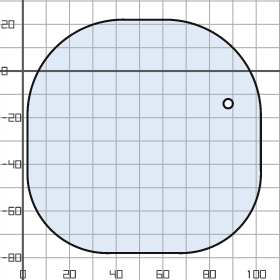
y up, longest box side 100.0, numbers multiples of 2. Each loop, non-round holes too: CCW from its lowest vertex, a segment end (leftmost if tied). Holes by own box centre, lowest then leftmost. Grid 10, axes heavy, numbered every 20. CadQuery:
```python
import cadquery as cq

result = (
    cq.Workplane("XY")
    .moveTo(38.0, -78.0)
    .lineTo(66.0, -78.0)
    .threePointArc((92.0, -68.0), (102.0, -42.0))
    .lineTo(102.0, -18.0)
    .threePointArc((90.0, 10.0), (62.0, 22.0))
    .lineTo(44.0, 22.0)
    .threePointArc((14.0, 10.0), (2.0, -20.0))
    .lineTo(2.0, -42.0)
    .threePointArc((12.0, -68.0), (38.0, -78.0))
    .close()
    .moveTo(88.0, -14.0)
    .circle(2.0)
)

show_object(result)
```